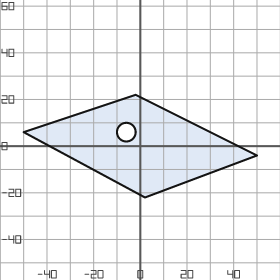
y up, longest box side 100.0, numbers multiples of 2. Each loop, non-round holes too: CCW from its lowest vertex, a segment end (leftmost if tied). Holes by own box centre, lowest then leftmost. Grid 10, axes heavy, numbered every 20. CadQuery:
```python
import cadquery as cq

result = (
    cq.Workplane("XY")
    .moveTo(2.0, -22.0)
    .lineTo(50.0, -4.0)
    .lineTo(-2.0, 22.0)
    .lineTo(-50.0, 6.0)
    .close()
    .moveTo(-6.0, 6.0)
    .circle(4.0)
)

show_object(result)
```